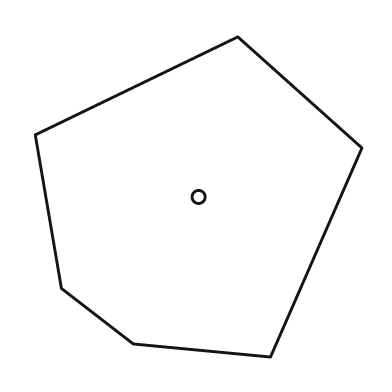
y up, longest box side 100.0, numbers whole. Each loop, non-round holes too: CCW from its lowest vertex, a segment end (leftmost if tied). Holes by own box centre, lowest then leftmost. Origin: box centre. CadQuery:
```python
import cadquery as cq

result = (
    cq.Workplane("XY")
    .moveTo(22.0, -49.0)
    .lineTo(50.0, 15.0)
    .lineTo(12.0, 49.0)
    .lineTo(-50.0, 19.0)
    .lineTo(-42.0, -28.0)
    .lineTo(-20.0, -45.0)
    .close()
    .moveTo(0.0, 0.0)
    .circle(2.0)
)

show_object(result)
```